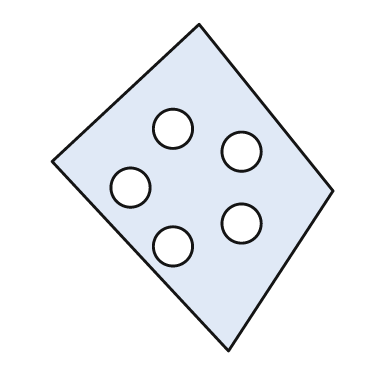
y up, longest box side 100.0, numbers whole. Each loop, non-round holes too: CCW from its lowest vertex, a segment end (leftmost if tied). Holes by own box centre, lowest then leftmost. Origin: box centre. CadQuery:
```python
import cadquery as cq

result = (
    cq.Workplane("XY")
    .moveTo(11.0, -50.0)
    .lineTo(43.0, -1.0)
    .lineTo(2.0, 50.0)
    .lineTo(-43.0, 8.0)
    .close()
    .moveTo(-6.0, -18.0)
    .circle(6.0)
    .moveTo(15.0, -11.0)
    .circle(6.0)
    .moveTo(-19.0, 0.0)
    .circle(6.0)
    .moveTo(15.0, 11.0)
    .circle(6.0)
    .moveTo(-6.0, 18.0)
    .circle(6.0)
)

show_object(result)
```